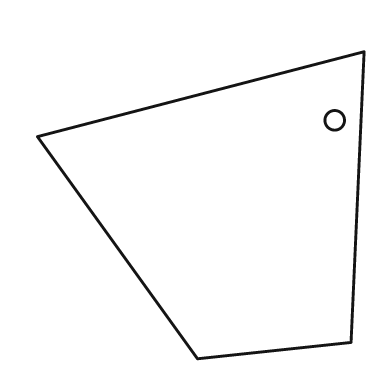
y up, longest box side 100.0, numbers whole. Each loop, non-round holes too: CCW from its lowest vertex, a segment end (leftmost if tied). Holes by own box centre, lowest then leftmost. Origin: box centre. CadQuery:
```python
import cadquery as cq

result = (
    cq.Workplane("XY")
    .moveTo(-1.0, -47.0)
    .lineTo(46.0, -42.0)
    .lineTo(50.0, 47.0)
    .lineTo(-50.0, 21.0)
    .close()
    .moveTo(41.0, 26.0)
    .circle(3.0)
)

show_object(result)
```